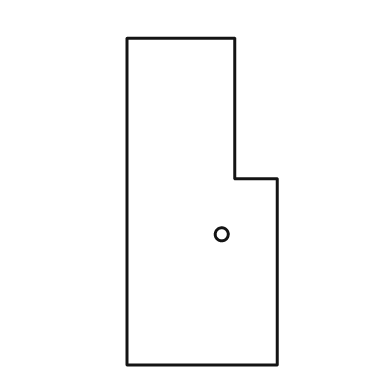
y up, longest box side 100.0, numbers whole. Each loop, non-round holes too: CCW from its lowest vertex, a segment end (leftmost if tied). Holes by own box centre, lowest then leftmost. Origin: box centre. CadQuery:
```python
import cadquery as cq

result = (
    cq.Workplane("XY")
    .moveTo(-23.0, -50.0)
    .lineTo(23.0, -50.0)
    .lineTo(23.0, 7.0)
    .lineTo(10.0, 7.0)
    .lineTo(10.0, 50.0)
    .lineTo(-23.0, 50.0)
    .close()
    .moveTo(6.0, -10.0)
    .circle(2.0)
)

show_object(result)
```